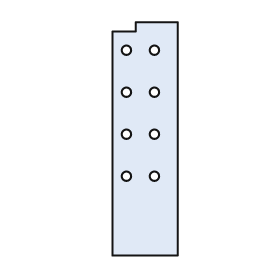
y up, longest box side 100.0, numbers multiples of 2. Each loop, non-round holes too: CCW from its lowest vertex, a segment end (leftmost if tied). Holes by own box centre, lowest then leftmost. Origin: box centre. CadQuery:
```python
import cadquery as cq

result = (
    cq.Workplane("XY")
    .moveTo(-14.0, -50.0)
    .lineTo(14.0, -50.0)
    .lineTo(14.0, 50.0)
    .lineTo(-4.0, 50.0)
    .lineTo(-4.0, 46.0)
    .lineTo(-14.0, 46.0)
    .close()
    .moveTo(-8.0, -16.0)
    .circle(2.0)
    .moveTo(4.0, -16.0)
    .circle(2.0)
    .moveTo(-8.0, 2.0)
    .circle(2.0)
    .moveTo(4.0, 2.0)
    .circle(2.0)
    .moveTo(-8.0, 20.0)
    .circle(2.0)
    .moveTo(4.0, 20.0)
    .circle(2.0)
    .moveTo(-8.0, 38.0)
    .circle(2.0)
    .moveTo(4.0, 38.0)
    .circle(2.0)
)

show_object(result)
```